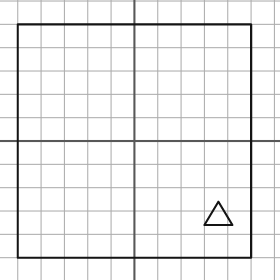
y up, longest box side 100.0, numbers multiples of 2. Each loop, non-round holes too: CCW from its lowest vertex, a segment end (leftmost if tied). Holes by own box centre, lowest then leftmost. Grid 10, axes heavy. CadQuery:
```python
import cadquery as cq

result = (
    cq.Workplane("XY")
    .moveTo(-50.0, -50.0)
    .lineTo(50.0, -50.0)
    .lineTo(50.0, 50.0)
    .lineTo(-50.0, 50.0)
    .close()
    .moveTo(30.0, -36.0)
    .lineTo(42.0, -36.0)
    .lineTo(36.0, -26.0)
    .close()
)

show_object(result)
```